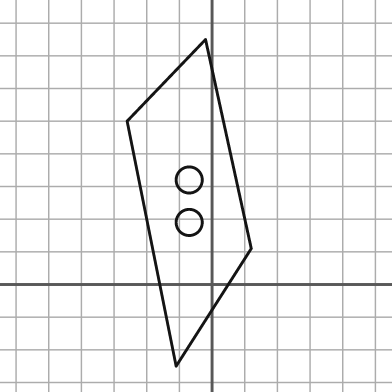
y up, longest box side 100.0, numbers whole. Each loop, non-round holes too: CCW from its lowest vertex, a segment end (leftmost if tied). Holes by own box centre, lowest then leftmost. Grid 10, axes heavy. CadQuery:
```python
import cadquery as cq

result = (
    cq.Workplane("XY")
    .moveTo(-11.0, -25.0)
    .lineTo(12.0, 11.0)
    .lineTo(-2.0, 75.0)
    .lineTo(-26.0, 50.0)
    .close()
    .moveTo(-7.0, 19.0)
    .circle(4.0)
    .moveTo(-7.0, 32.0)
    .circle(4.0)
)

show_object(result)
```